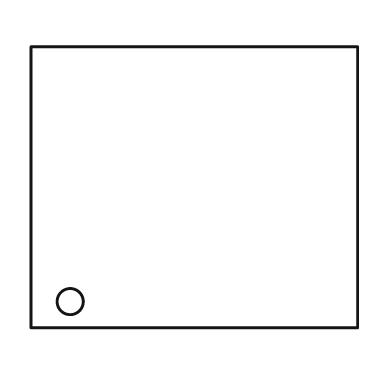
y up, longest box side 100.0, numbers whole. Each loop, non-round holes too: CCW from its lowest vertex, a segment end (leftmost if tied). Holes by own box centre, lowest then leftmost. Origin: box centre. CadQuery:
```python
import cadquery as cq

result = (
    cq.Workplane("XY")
    .moveTo(-50.0, -43.0)
    .lineTo(50.0, -43.0)
    .lineTo(50.0, 43.0)
    .lineTo(-50.0, 43.0)
    .close()
    .moveTo(-38.0, -35.0)
    .circle(4.0)
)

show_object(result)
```